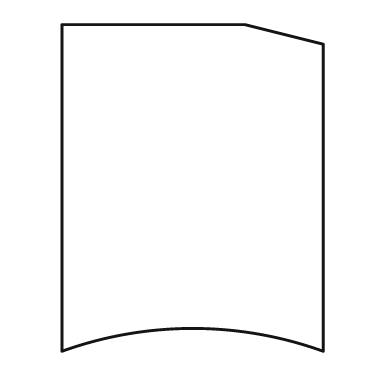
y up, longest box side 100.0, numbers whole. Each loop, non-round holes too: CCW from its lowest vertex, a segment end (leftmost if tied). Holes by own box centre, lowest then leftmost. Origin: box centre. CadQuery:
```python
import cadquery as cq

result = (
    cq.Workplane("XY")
    .moveTo(-40.0, -50.0)
    .threePointArc((0.0, -43.0), (40.0, -50.0))
    .lineTo(40.0, 44.0)
    .lineTo(16.0, 50.0)
    .lineTo(-40.0, 50.0)
    .close()
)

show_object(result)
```